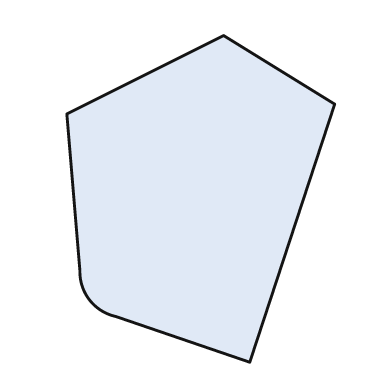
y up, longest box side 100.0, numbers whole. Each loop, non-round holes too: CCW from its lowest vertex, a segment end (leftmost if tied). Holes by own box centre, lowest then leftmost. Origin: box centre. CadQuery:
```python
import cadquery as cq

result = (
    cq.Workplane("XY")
    .moveTo(15.0, -50.0)
    .lineTo(41.0, 29.0)
    .lineTo(7.0, 50.0)
    .lineTo(-41.0, 26.0)
    .lineTo(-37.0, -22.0)
    .threePointArc((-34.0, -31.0), (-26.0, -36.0))
    .close()
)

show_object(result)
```